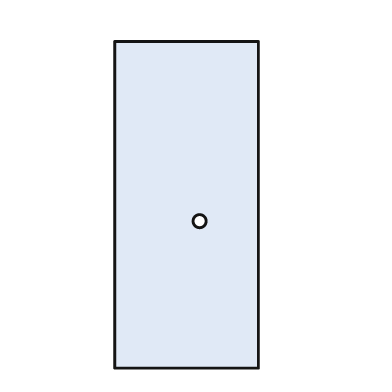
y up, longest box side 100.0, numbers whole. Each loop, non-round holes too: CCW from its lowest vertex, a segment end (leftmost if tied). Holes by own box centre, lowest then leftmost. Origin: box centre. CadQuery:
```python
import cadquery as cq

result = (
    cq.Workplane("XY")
    .moveTo(-22.0, -50.0)
    .lineTo(22.0, -50.0)
    .lineTo(22.0, 50.0)
    .lineTo(-22.0, 50.0)
    .close()
    .moveTo(4.0, -5.0)
    .circle(2.0)
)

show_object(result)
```